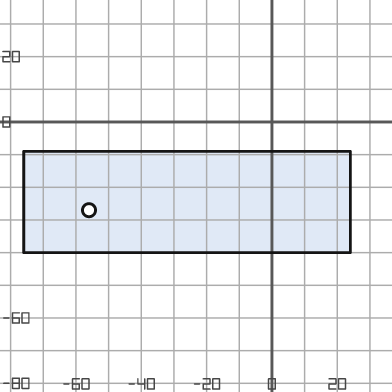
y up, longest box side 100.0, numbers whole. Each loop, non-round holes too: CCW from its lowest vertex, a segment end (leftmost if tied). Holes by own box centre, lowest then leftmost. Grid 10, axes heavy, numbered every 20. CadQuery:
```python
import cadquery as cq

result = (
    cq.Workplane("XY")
    .moveTo(-76.0, -40.0)
    .lineTo(24.0, -40.0)
    .lineTo(24.0, -9.0)
    .lineTo(-76.0, -9.0)
    .close()
    .moveTo(-56.0, -27.0)
    .circle(2.0)
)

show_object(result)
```